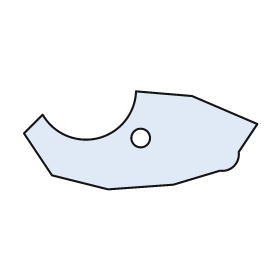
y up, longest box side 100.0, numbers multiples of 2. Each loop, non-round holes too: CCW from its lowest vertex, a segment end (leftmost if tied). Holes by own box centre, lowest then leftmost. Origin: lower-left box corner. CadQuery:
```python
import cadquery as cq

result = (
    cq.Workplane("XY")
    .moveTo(36.0, 0.0)
    .lineTo(64.0, 2.0)
    .lineTo(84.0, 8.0)
    .threePointArc((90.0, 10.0), (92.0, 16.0))
    .lineTo(100.0, 28.0)
    .lineTo(72.0, 40.0)
    .lineTo(48.0, 42.0)
    .threePointArc((32.0, 22.0), (8.0, 32.0))
    .lineTo(0.0, 24.0)
    .lineTo(12.0, 6.0)
    .close()
    .moveTo(50.0, 22.0)
    .circle(4.0)
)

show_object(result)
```